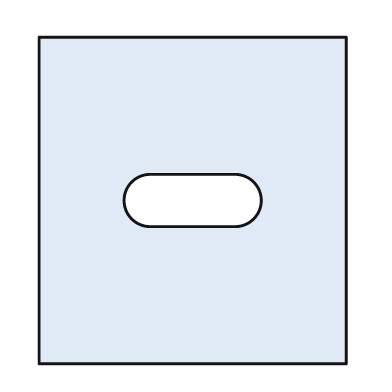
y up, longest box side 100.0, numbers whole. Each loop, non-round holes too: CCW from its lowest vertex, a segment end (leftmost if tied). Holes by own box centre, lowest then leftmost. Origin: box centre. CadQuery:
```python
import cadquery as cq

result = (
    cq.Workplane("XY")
    .moveTo(-47.0, -50.0)
    .lineTo(47.0, -50.0)
    .lineTo(47.0, 50.0)
    .lineTo(-47.0, 50.0)
    .close()
    .moveTo(-13.0, -8.0)
    .lineTo(13.0, -8.0)
    .threePointArc((21.0, 0.0), (13.0, 8.0))
    .lineTo(-13.0, 8.0)
    .threePointArc((-21.0, 0.0), (-13.0, -8.0))
    .close()
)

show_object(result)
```